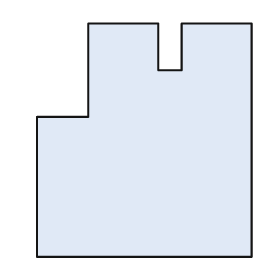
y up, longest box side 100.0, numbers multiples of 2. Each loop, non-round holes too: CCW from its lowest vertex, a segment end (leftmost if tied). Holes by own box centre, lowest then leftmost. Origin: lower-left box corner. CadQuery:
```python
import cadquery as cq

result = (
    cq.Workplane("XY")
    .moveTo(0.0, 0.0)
    .lineTo(92.0, 0.0)
    .lineTo(92.0, 100.0)
    .lineTo(62.0, 100.0)
    .lineTo(62.0, 80.0)
    .lineTo(52.0, 80.0)
    .lineTo(52.0, 100.0)
    .lineTo(22.0, 100.0)
    .lineTo(22.0, 60.0)
    .lineTo(0.0, 60.0)
    .close()
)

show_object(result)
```